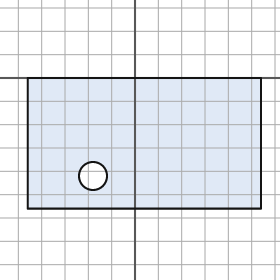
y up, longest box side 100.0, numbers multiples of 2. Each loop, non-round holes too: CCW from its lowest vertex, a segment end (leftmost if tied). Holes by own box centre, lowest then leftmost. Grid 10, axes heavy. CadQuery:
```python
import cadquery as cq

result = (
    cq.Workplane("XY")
    .moveTo(-46.0, -56.0)
    .lineTo(54.0, -56.0)
    .lineTo(54.0, 0.0)
    .lineTo(-46.0, 0.0)
    .close()
    .moveTo(-18.0, -42.0)
    .circle(6.0)
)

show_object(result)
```